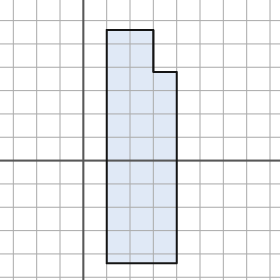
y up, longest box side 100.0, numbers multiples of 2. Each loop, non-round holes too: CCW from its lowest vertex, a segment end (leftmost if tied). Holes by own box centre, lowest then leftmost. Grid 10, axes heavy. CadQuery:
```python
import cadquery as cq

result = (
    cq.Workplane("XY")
    .moveTo(10.0, -44.0)
    .lineTo(40.0, -44.0)
    .lineTo(40.0, 38.0)
    .lineTo(30.0, 38.0)
    .lineTo(30.0, 56.0)
    .lineTo(10.0, 56.0)
    .close()
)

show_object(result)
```